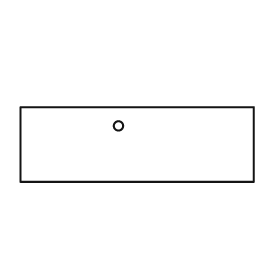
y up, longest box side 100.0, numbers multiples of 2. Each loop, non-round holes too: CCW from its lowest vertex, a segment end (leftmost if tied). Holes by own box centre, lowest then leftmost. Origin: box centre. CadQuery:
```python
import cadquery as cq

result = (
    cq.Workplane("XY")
    .moveTo(-50.0, -16.0)
    .lineTo(50.0, -16.0)
    .lineTo(50.0, 16.0)
    .lineTo(-50.0, 16.0)
    .close()
    .moveTo(-8.0, 8.0)
    .circle(2.0)
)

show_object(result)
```